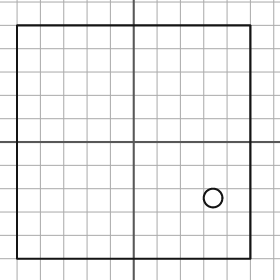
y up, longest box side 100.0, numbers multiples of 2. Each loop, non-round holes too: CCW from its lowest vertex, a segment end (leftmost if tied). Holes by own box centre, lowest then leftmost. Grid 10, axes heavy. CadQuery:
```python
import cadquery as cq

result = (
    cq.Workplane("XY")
    .moveTo(-50.0, -50.0)
    .lineTo(50.0, -50.0)
    .lineTo(50.0, 50.0)
    .lineTo(-50.0, 50.0)
    .close()
    .moveTo(34.0, -24.0)
    .circle(4.0)
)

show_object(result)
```